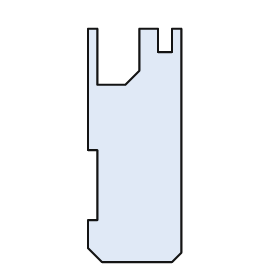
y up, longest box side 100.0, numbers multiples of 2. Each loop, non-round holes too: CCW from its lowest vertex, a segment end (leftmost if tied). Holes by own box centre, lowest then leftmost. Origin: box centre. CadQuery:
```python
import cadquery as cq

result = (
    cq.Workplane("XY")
    .moveTo(-14.0, -50.0)
    .lineTo(16.0, -50.0)
    .lineTo(20.0, -46.0)
    .lineTo(20.0, 50.0)
    .lineTo(16.0, 50.0)
    .lineTo(16.0, 40.0)
    .lineTo(10.0, 40.0)
    .lineTo(10.0, 50.0)
    .lineTo(2.0, 50.0)
    .lineTo(2.0, 32.0)
    .lineTo(-4.0, 26.0)
    .lineTo(-16.0, 26.0)
    .lineTo(-16.0, 50.0)
    .lineTo(-20.0, 50.0)
    .lineTo(-20.0, -2.0)
    .lineTo(-16.0, -2.0)
    .lineTo(-16.0, -32.0)
    .lineTo(-20.0, -32.0)
    .lineTo(-20.0, -44.0)
    .close()
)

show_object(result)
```